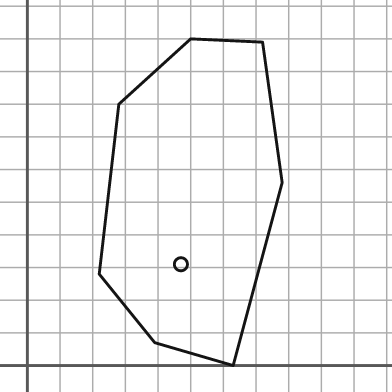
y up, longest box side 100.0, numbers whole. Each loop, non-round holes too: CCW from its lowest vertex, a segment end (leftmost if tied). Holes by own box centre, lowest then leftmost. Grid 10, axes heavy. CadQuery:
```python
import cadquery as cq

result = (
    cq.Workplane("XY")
    .moveTo(63.0, 0.0)
    .lineTo(78.0, 56.0)
    .lineTo(72.0, 99.0)
    .lineTo(50.0, 100.0)
    .lineTo(28.0, 80.0)
    .lineTo(22.0, 28.0)
    .lineTo(39.0, 7.0)
    .close()
    .moveTo(47.0, 31.0)
    .circle(2.0)
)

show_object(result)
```